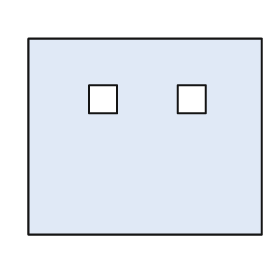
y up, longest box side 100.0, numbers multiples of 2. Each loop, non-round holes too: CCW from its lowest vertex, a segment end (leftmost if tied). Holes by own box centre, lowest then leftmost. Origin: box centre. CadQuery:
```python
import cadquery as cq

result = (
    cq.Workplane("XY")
    .moveTo(-50.0, -42.0)
    .lineTo(50.0, -42.0)
    .lineTo(50.0, 42.0)
    .lineTo(-50.0, 42.0)
    .close()
    .moveTo(-24.0, 10.0)
    .lineTo(-12.0, 10.0)
    .lineTo(-12.0, 22.0)
    .lineTo(-24.0, 22.0)
    .close()
    .moveTo(14.0, 10.0)
    .lineTo(26.0, 10.0)
    .lineTo(26.0, 22.0)
    .lineTo(14.0, 22.0)
    .close()
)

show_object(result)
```